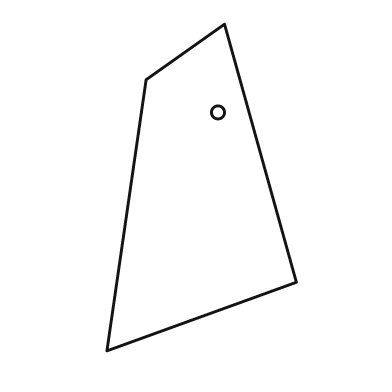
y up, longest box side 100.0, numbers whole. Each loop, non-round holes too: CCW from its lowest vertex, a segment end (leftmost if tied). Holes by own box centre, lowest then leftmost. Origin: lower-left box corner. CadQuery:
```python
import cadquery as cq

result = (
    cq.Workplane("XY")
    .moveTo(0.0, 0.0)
    .lineTo(58.0, 21.0)
    .lineTo(36.0, 100.0)
    .lineTo(12.0, 83.0)
    .close()
    .moveTo(34.0, 73.0)
    .circle(2.0)
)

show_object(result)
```